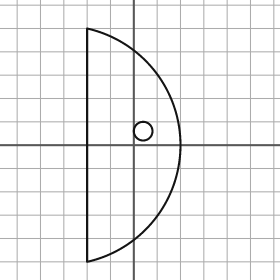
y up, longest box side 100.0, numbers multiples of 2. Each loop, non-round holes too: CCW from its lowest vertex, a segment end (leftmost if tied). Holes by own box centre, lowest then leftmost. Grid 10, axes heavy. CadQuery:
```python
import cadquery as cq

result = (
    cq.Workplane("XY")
    .moveTo(-20.0, -50.0)
    .threePointArc((20.0, 0.0), (-20.0, 50.0))
    .close()
    .moveTo(4.0, 6.0)
    .circle(4.0)
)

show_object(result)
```